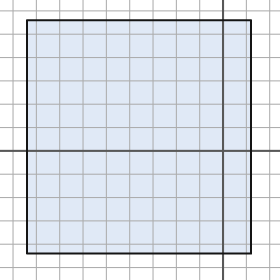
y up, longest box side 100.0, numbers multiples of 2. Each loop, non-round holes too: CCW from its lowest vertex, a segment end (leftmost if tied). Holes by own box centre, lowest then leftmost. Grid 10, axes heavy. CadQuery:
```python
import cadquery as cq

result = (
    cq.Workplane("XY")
    .moveTo(-84.0, -44.0)
    .lineTo(12.0, -44.0)
    .lineTo(12.0, 56.0)
    .lineTo(-84.0, 56.0)
    .close()
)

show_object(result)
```